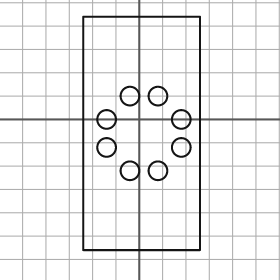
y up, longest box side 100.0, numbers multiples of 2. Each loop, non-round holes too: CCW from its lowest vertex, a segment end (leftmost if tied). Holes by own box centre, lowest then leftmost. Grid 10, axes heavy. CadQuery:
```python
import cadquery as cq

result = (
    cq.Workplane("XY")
    .moveTo(-24.0, -56.0)
    .lineTo(26.0, -56.0)
    .lineTo(26.0, 44.0)
    .lineTo(-24.0, 44.0)
    .close()
    .moveTo(-4.0, -22.0)
    .circle(4.0)
    .moveTo(8.0, -22.0)
    .circle(4.0)
    .moveTo(-14.0, -12.0)
    .circle(4.0)
    .moveTo(18.0, -12.0)
    .circle(4.0)
    .moveTo(-14.0, 0.0)
    .circle(4.0)
    .moveTo(18.0, 0.0)
    .circle(4.0)
    .moveTo(-4.0, 10.0)
    .circle(4.0)
    .moveTo(8.0, 10.0)
    .circle(4.0)
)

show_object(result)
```